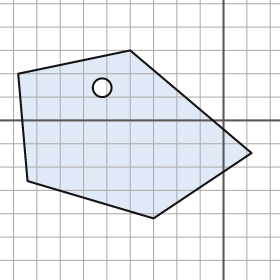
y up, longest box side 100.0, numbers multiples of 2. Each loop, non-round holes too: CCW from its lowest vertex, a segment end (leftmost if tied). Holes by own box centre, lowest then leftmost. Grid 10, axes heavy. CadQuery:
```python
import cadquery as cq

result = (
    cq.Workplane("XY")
    .moveTo(-30.0, -42.0)
    .lineTo(12.0, -14.0)
    .lineTo(-40.0, 30.0)
    .lineTo(-88.0, 20.0)
    .lineTo(-84.0, -26.0)
    .close()
    .moveTo(-52.0, 14.0)
    .circle(4.0)
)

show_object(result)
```